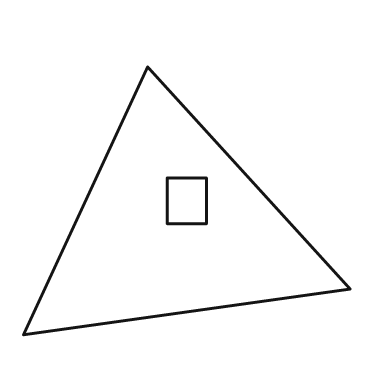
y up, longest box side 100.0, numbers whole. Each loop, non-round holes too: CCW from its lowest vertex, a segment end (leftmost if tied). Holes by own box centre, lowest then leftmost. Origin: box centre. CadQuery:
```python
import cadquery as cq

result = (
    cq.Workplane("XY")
    .moveTo(-50.0, -41.0)
    .lineTo(50.0, -27.0)
    .lineTo(-12.0, 41.0)
    .close()
    .moveTo(-6.0, -7.0)
    .lineTo(6.0, -7.0)
    .lineTo(6.0, 7.0)
    .lineTo(-6.0, 7.0)
    .close()
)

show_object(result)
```